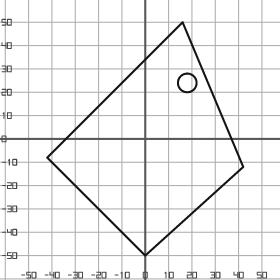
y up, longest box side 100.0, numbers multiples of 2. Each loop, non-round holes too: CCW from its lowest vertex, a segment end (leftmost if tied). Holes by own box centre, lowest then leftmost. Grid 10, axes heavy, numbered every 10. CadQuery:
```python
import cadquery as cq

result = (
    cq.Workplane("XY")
    .moveTo(0.0, -50.0)
    .lineTo(42.0, -12.0)
    .lineTo(16.0, 50.0)
    .lineTo(-42.0, -8.0)
    .close()
    .moveTo(18.0, 24.0)
    .circle(4.0)
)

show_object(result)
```